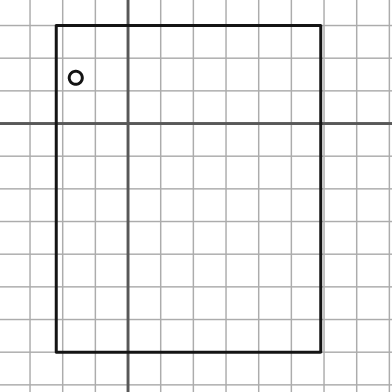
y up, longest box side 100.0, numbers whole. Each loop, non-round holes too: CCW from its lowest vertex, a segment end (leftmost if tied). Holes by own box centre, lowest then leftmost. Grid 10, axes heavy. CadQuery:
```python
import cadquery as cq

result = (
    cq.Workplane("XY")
    .moveTo(-22.0, -70.0)
    .lineTo(59.0, -70.0)
    .lineTo(59.0, 30.0)
    .lineTo(-22.0, 30.0)
    .close()
    .moveTo(-16.0, 14.0)
    .circle(2.0)
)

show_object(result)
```